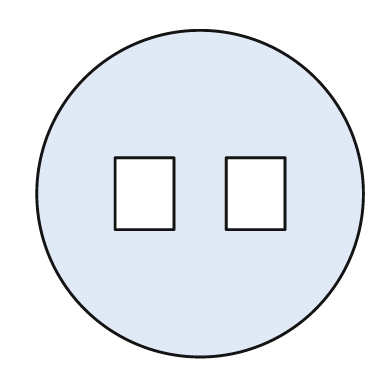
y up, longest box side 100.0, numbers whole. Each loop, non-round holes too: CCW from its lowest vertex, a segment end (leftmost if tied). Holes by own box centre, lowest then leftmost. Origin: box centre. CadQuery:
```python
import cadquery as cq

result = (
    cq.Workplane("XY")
    .moveTo(0.0, 0.0)
    .circle(50.0)
    .moveTo(-26.0, -11.0)
    .lineTo(-8.0, -11.0)
    .lineTo(-8.0, 11.0)
    .lineTo(-26.0, 11.0)
    .close()
    .moveTo(8.0, -11.0)
    .lineTo(26.0, -11.0)
    .lineTo(26.0, 11.0)
    .lineTo(8.0, 11.0)
    .close()
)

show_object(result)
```